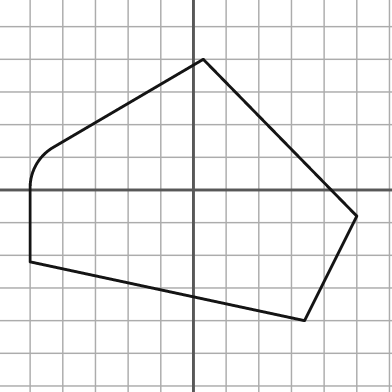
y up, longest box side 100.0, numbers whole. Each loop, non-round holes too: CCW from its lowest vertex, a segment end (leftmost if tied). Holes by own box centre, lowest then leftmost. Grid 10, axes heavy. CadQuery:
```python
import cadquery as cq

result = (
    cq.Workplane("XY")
    .moveTo(34.0, -40.0)
    .lineTo(50.0, -8.0)
    .lineTo(3.0, 40.0)
    .lineTo(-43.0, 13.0)
    .threePointArc((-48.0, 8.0), (-50.0, 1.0))
    .lineTo(-50.0, -22.0)
    .close()
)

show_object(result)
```